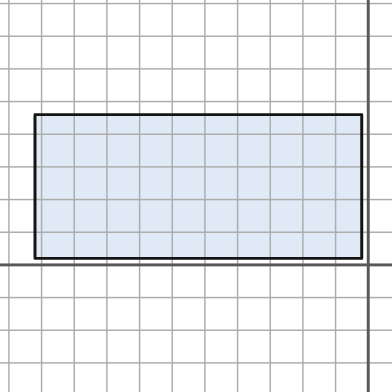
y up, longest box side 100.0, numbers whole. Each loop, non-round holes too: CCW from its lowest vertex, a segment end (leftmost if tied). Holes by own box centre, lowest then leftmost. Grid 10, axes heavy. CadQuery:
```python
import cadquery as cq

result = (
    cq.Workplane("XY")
    .moveTo(-102.0, 2.0)
    .lineTo(-2.0, 2.0)
    .lineTo(-2.0, 46.0)
    .lineTo(-102.0, 46.0)
    .close()
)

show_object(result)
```